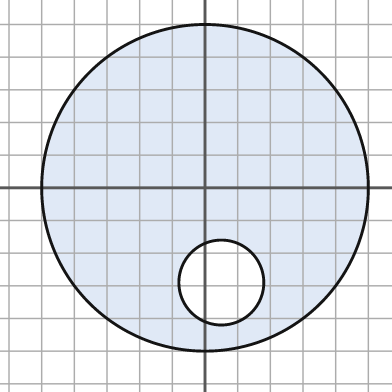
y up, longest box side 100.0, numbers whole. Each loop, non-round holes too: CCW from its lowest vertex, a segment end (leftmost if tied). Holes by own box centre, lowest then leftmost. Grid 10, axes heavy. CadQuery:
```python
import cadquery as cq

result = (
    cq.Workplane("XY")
    .moveTo(0.0, 0.0)
    .circle(50.0)
    .moveTo(5.0, -29.0)
    .circle(13.0)
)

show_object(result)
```